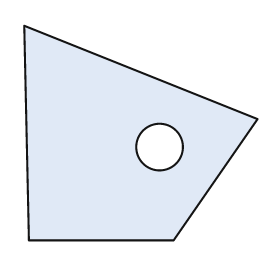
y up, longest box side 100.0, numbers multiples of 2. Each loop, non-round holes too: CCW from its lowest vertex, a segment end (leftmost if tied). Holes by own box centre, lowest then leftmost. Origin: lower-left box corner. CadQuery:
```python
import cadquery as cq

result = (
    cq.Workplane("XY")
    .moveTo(2.0, 0.0)
    .lineTo(64.0, 0.0)
    .lineTo(100.0, 52.0)
    .lineTo(0.0, 92.0)
    .close()
    .moveTo(58.0, 40.0)
    .circle(10.0)
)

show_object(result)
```